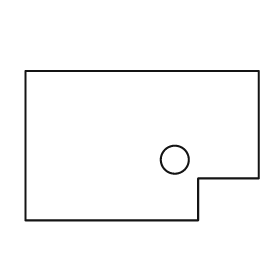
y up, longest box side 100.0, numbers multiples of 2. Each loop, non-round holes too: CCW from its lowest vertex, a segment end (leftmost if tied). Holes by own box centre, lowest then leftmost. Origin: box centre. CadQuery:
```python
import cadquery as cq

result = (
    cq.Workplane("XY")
    .moveTo(-50.0, -32.0)
    .lineTo(24.0, -32.0)
    .lineTo(24.0, -14.0)
    .lineTo(50.0, -14.0)
    .lineTo(50.0, 32.0)
    .lineTo(-50.0, 32.0)
    .close()
    .moveTo(14.0, -6.0)
    .circle(6.0)
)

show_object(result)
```